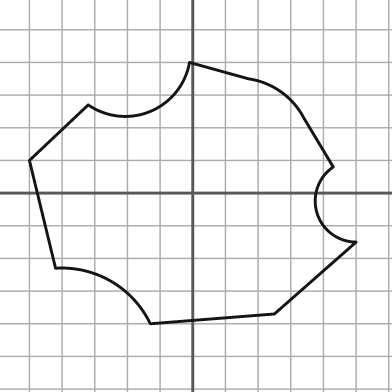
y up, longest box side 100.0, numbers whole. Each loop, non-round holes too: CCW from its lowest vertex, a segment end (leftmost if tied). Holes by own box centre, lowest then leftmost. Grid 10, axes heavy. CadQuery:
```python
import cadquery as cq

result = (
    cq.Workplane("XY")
    .moveTo(-13.0, -40.0)
    .lineTo(25.0, -37.0)
    .lineTo(50.0, -15.0)
    .threePointArc((38.0, -6.0), (43.0, 8.0))
    .lineTo(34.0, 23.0)
    .threePointArc((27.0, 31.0), (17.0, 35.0))
    .lineTo(-1.0, 40.0)
    .threePointArc((-13.0, 25.0), (-32.0, 27.0))
    .lineTo(-50.0, 10.0)
    .lineTo(-42.0, -23.0)
    .threePointArc((-25.0, -27.0), (-13.0, -40.0))
    .close()
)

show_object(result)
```